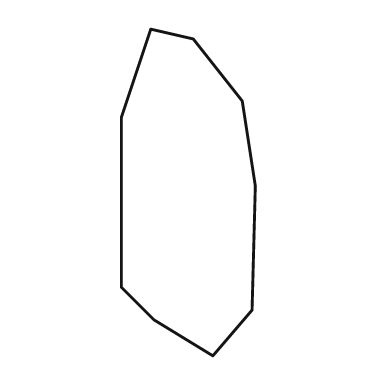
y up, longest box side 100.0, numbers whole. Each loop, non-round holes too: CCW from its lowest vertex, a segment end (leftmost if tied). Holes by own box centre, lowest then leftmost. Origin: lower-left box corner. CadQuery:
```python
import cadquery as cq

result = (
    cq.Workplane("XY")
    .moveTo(28.0, 0.0)
    .lineTo(40.0, 14.0)
    .lineTo(41.0, 52.0)
    .lineTo(37.0, 78.0)
    .lineTo(22.0, 97.0)
    .lineTo(9.0, 100.0)
    .lineTo(0.0, 73.0)
    .lineTo(0.0, 21.0)
    .lineTo(10.0, 11.0)
    .close()
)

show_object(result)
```